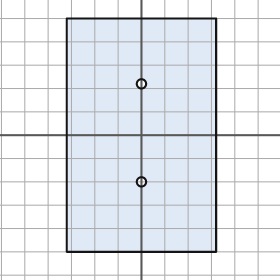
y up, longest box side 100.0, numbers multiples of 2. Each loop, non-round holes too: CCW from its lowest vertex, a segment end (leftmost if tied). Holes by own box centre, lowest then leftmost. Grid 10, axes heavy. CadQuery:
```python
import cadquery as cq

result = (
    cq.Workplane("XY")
    .moveTo(-32.0, -50.0)
    .lineTo(32.0, -50.0)
    .lineTo(32.0, 50.0)
    .lineTo(-32.0, 50.0)
    .close()
    .moveTo(0.0, -20.0)
    .circle(2.0)
    .moveTo(0.0, 22.0)
    .circle(2.0)
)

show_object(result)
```